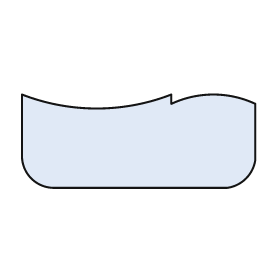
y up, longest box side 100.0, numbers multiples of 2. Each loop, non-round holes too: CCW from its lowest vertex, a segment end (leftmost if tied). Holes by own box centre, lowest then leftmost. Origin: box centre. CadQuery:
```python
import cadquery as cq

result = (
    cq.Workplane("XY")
    .moveTo(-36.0, -20.0)
    .lineTo(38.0, -20.0)
    .threePointArc((46.0, -16.0), (50.0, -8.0))
    .lineTo(50.0, 16.0)
    .threePointArc((32.0, 20.0), (14.0, 16.0))
    .lineTo(14.0, 20.0)
    .threePointArc((-18.0, 14.0), (-50.0, 20.0))
    .lineTo(-50.0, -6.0)
    .threePointArc((-46.0, -16.0), (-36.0, -20.0))
    .close()
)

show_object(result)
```